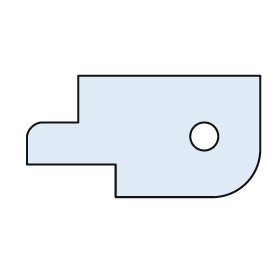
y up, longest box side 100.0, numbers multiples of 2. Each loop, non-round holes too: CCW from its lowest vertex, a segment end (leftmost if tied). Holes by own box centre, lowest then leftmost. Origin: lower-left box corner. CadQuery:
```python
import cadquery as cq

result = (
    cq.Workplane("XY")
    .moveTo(38.0, 0.0)
    .lineTo(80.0, 0.0)
    .threePointArc((94.0, 6.0), (100.0, 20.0))
    .lineTo(100.0, 52.0)
    .lineTo(22.0, 52.0)
    .lineTo(22.0, 32.0)
    .lineTo(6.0, 32.0)
    .threePointArc((2.0, 30.0), (0.0, 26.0))
    .lineTo(0.0, 14.0)
    .lineTo(38.0, 14.0)
    .close()
    .moveTo(76.0, 26.0)
    .circle(6.0)
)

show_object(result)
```